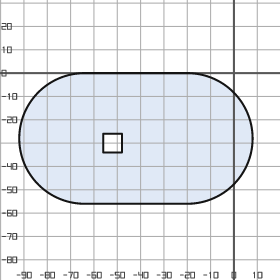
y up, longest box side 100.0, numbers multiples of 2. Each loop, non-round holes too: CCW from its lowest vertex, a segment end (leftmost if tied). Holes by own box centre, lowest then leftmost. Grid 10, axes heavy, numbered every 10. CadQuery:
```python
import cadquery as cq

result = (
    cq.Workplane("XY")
    .moveTo(-64.0, -56.0)
    .lineTo(-20.0, -56.0)
    .threePointArc((8.0, -28.0), (-20.0, 0.0))
    .lineTo(-64.0, 0.0)
    .threePointArc((-92.0, -28.0), (-64.0, -56.0))
    .close()
    .moveTo(-56.0, -34.0)
    .lineTo(-48.0, -34.0)
    .lineTo(-48.0, -26.0)
    .lineTo(-56.0, -26.0)
    .close()
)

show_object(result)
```